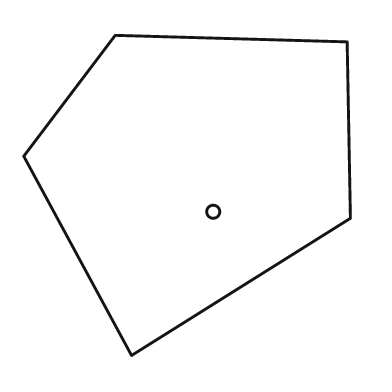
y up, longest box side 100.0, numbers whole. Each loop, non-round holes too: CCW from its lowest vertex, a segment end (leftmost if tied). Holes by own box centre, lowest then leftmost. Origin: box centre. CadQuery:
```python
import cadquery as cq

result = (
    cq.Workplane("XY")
    .moveTo(-17.0, -49.0)
    .lineTo(50.0, -7.0)
    .lineTo(49.0, 47.0)
    .lineTo(-22.0, 49.0)
    .lineTo(-50.0, 12.0)
    .close()
    .moveTo(8.0, -5.0)
    .circle(2.0)
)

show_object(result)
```